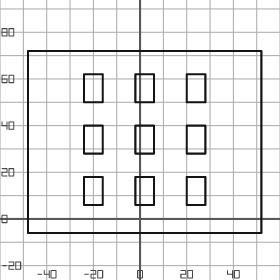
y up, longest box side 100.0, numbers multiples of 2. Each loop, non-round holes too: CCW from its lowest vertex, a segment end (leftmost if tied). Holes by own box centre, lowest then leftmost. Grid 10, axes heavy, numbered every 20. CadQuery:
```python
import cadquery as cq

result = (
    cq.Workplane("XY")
    .moveTo(-48.0, -6.0)
    .lineTo(52.0, -6.0)
    .lineTo(52.0, 72.0)
    .lineTo(-48.0, 72.0)
    .close()
    .moveTo(-24.0, 6.0)
    .lineTo(-16.0, 6.0)
    .lineTo(-16.0, 18.0)
    .lineTo(-24.0, 18.0)
    .close()
    .moveTo(-2.0, 6.0)
    .lineTo(6.0, 6.0)
    .lineTo(6.0, 18.0)
    .lineTo(-2.0, 18.0)
    .close()
    .moveTo(20.0, 6.0)
    .lineTo(28.0, 6.0)
    .lineTo(28.0, 18.0)
    .lineTo(20.0, 18.0)
    .close()
    .moveTo(-24.0, 28.0)
    .lineTo(-16.0, 28.0)
    .lineTo(-16.0, 40.0)
    .lineTo(-24.0, 40.0)
    .close()
    .moveTo(-2.0, 28.0)
    .lineTo(6.0, 28.0)
    .lineTo(6.0, 40.0)
    .lineTo(-2.0, 40.0)
    .close()
    .moveTo(20.0, 28.0)
    .lineTo(28.0, 28.0)
    .lineTo(28.0, 40.0)
    .lineTo(20.0, 40.0)
    .close()
    .moveTo(-24.0, 50.0)
    .lineTo(-16.0, 50.0)
    .lineTo(-16.0, 62.0)
    .lineTo(-24.0, 62.0)
    .close()
    .moveTo(-2.0, 50.0)
    .lineTo(6.0, 50.0)
    .lineTo(6.0, 62.0)
    .lineTo(-2.0, 62.0)
    .close()
    .moveTo(20.0, 50.0)
    .lineTo(28.0, 50.0)
    .lineTo(28.0, 62.0)
    .lineTo(20.0, 62.0)
    .close()
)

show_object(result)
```